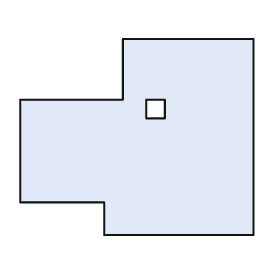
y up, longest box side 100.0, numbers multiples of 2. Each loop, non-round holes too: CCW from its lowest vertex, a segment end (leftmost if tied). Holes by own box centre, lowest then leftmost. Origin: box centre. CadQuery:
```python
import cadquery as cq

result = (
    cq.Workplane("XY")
    .moveTo(-14.0, -42.0)
    .lineTo(50.0, -42.0)
    .lineTo(50.0, 42.0)
    .lineTo(-6.0, 42.0)
    .lineTo(-6.0, 16.0)
    .lineTo(-50.0, 16.0)
    .lineTo(-50.0, -28.0)
    .lineTo(-14.0, -28.0)
    .close()
    .moveTo(4.0, 8.0)
    .lineTo(12.0, 8.0)
    .lineTo(12.0, 16.0)
    .lineTo(4.0, 16.0)
    .close()
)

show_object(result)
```